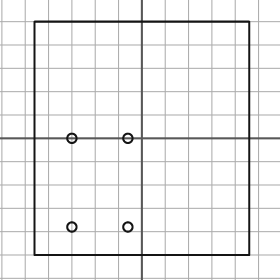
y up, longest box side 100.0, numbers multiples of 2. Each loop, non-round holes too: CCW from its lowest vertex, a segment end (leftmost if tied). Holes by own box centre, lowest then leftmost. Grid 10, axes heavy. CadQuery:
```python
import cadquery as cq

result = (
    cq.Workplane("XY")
    .moveTo(-46.0, -50.0)
    .lineTo(46.0, -50.0)
    .lineTo(46.0, 50.0)
    .lineTo(-46.0, 50.0)
    .close()
    .moveTo(-30.0, -38.0)
    .circle(2.0)
    .moveTo(-6.0, -38.0)
    .circle(2.0)
    .moveTo(-30.0, 0.0)
    .circle(2.0)
    .moveTo(-6.0, 0.0)
    .circle(2.0)
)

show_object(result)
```